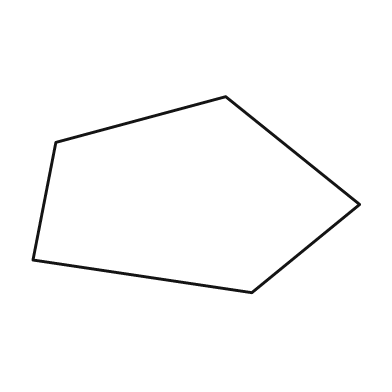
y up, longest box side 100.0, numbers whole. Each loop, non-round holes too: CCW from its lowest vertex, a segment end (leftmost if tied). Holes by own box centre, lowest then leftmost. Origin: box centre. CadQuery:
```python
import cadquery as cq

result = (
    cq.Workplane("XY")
    .moveTo(17.0, -30.0)
    .lineTo(50.0, -3.0)
    .lineTo(9.0, 30.0)
    .lineTo(-43.0, 16.0)
    .lineTo(-50.0, -20.0)
    .close()
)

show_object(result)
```